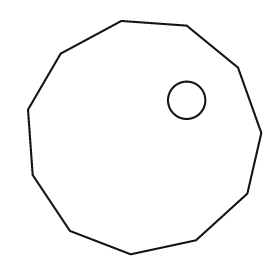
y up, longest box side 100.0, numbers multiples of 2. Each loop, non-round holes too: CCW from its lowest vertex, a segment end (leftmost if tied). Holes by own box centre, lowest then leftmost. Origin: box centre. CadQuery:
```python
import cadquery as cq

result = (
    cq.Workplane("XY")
    .moveTo(-6.0, -50.0)
    .lineTo(22.0, -44.0)
    .lineTo(44.0, -24.0)
    .lineTo(50.0, 2.0)
    .lineTo(40.0, 30.0)
    .lineTo(18.0, 48.0)
    .lineTo(-10.0, 50.0)
    .lineTo(-36.0, 36.0)
    .lineTo(-50.0, 12.0)
    .lineTo(-48.0, -16.0)
    .lineTo(-32.0, -40.0)
    .close()
    .moveTo(18.0, 16.0)
    .circle(8.0)
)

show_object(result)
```